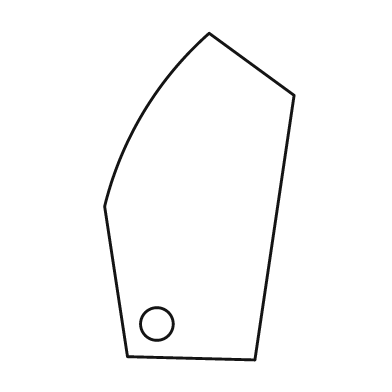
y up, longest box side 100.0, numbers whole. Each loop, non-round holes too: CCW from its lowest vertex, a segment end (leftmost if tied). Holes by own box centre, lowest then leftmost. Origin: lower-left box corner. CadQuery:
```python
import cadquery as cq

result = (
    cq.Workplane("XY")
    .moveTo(46.0, 0.0)
    .lineTo(58.0, 81.0)
    .lineTo(32.0, 100.0)
    .threePointArc((12.0, 76.0), (0.0, 47.0))
    .lineTo(7.0, 1.0)
    .close()
    .moveTo(16.0, 11.0)
    .circle(5.0)
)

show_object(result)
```